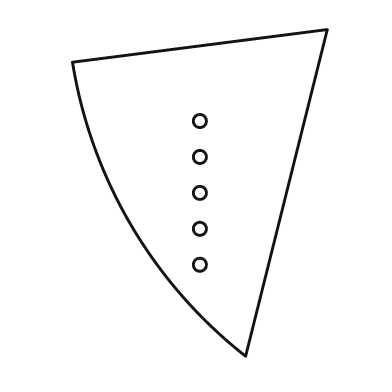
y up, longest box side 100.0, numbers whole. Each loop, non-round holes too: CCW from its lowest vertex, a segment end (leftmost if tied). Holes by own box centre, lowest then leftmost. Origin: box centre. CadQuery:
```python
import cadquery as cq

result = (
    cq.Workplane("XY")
    .moveTo(14.0, -50.0)
    .lineTo(39.0, 50.0)
    .lineTo(-39.0, 40.0)
    .threePointArc((-21.0, -10.0), (14.0, -50.0))
    .close()
    .moveTo(0.0, -22.0)
    .circle(2.0)
    .moveTo(0.0, -11.0)
    .circle(2.0)
    .moveTo(0.0, 0.0)
    .circle(2.0)
    .moveTo(0.0, 11.0)
    .circle(2.0)
    .moveTo(0.0, 22.0)
    .circle(2.0)
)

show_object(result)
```